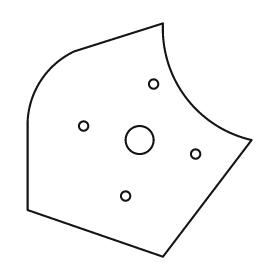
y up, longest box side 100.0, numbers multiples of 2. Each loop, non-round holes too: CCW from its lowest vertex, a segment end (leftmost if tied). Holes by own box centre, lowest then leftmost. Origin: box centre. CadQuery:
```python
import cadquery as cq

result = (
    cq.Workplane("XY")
    .moveTo(10.0, -50.0)
    .lineTo(48.0, 0.0)
    .threePointArc((20.0, 18.0), (10.0, 50.0))
    .lineTo(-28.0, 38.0)
    .threePointArc((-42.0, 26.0), (-48.0, 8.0))
    .lineTo(-48.0, -30.0)
    .close()
    .moveTo(-6.0, -24.0)
    .circle(2.0)
    .moveTo(24.0, -6.0)
    .circle(2.0)
    .moveTo(0.0, 0.0)
    .circle(6.0)
    .moveTo(-24.0, 6.0)
    .circle(2.0)
    .moveTo(6.0, 24.0)
    .circle(2.0)
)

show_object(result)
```